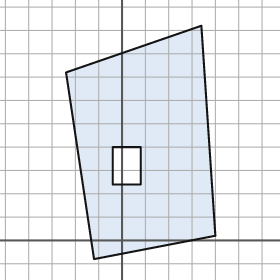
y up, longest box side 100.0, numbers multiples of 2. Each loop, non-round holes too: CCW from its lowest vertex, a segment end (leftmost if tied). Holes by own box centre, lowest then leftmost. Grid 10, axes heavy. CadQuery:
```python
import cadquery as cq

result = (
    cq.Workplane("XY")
    .moveTo(-12.0, -8.0)
    .lineTo(40.0, 2.0)
    .lineTo(34.0, 92.0)
    .lineTo(-24.0, 72.0)
    .close()
    .moveTo(-4.0, 24.0)
    .lineTo(8.0, 24.0)
    .lineTo(8.0, 40.0)
    .lineTo(-4.0, 40.0)
    .close()
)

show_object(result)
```